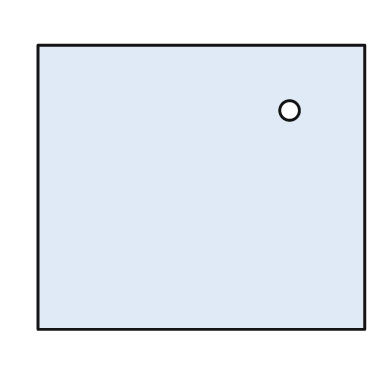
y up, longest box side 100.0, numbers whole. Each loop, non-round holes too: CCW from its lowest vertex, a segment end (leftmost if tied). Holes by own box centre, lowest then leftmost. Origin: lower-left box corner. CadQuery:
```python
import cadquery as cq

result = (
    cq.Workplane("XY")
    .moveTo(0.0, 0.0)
    .lineTo(100.0, 0.0)
    .lineTo(100.0, 87.0)
    .lineTo(0.0, 87.0)
    .close()
    .moveTo(77.0, 67.0)
    .circle(3.0)
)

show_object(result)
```